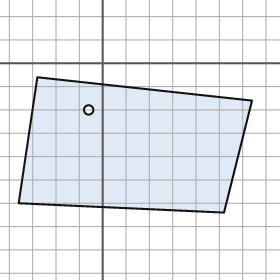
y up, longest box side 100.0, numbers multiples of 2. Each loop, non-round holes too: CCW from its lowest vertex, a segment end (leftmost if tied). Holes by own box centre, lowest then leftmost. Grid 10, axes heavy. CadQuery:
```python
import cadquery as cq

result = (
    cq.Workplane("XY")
    .moveTo(52.0, -64.0)
    .lineTo(64.0, -16.0)
    .lineTo(-28.0, -6.0)
    .lineTo(-36.0, -60.0)
    .close()
    .moveTo(-6.0, -20.0)
    .circle(2.0)
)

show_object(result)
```